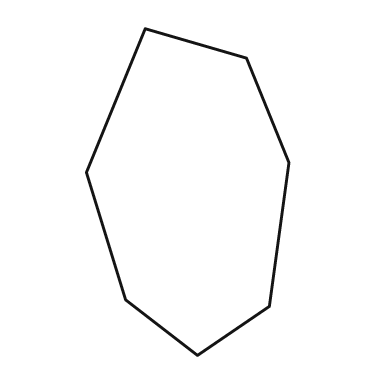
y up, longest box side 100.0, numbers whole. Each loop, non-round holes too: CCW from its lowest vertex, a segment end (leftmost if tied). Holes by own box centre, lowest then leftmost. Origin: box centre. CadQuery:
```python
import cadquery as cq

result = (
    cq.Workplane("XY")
    .moveTo(3.0, -50.0)
    .lineTo(25.0, -35.0)
    .lineTo(31.0, 9.0)
    .lineTo(18.0, 41.0)
    .lineTo(-13.0, 50.0)
    .lineTo(-31.0, 6.0)
    .lineTo(-19.0, -33.0)
    .close()
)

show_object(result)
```